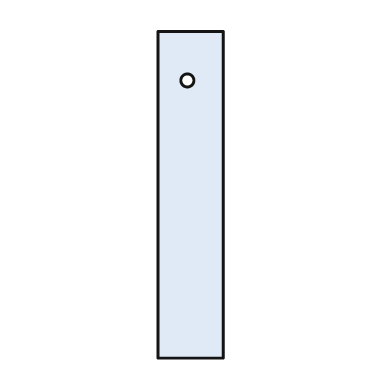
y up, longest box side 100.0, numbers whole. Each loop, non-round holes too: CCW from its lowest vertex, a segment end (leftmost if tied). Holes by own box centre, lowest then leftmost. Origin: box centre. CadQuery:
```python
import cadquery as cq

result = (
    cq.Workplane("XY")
    .moveTo(-10.0, -50.0)
    .lineTo(10.0, -50.0)
    .lineTo(10.0, 50.0)
    .lineTo(-10.0, 50.0)
    .close()
    .moveTo(-1.0, 35.0)
    .circle(2.0)
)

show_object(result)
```